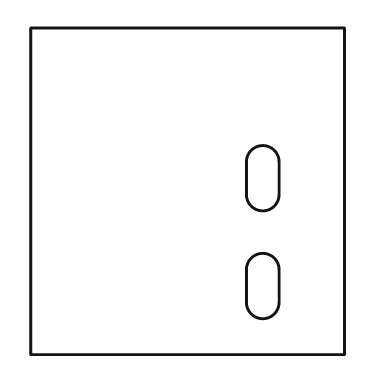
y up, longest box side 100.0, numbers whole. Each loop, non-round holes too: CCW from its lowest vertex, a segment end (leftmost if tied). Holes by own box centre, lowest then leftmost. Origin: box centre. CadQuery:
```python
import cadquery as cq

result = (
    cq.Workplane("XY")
    .moveTo(-48.0, -50.0)
    .lineTo(48.0, -50.0)
    .lineTo(48.0, 50.0)
    .lineTo(-48.0, 50.0)
    .close()
    .moveTo(18.0, -34.0)
    .threePointArc((23.0, -39.0), (28.0, -34.0))
    .lineTo(28.0, -24.0)
    .threePointArc((23.0, -19.0), (18.0, -24.0))
    .close()
    .moveTo(18.0, -1.0)
    .threePointArc((23.0, -6.0), (28.0, -1.0))
    .lineTo(28.0, 9.0)
    .threePointArc((23.0, 14.0), (18.0, 9.0))
    .close()
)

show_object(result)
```